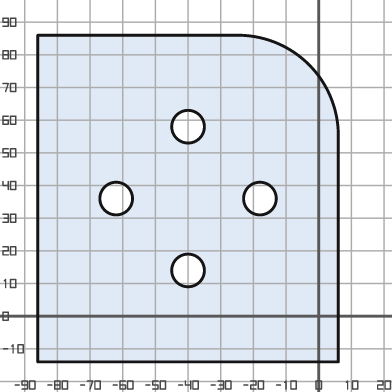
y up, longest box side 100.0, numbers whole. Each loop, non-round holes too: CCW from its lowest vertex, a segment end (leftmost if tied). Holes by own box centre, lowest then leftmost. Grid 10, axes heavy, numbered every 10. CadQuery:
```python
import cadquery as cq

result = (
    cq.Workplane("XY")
    .moveTo(-86.0, -14.0)
    .lineTo(6.0, -14.0)
    .lineTo(6.0, 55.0)
    .threePointArc((-3.0, 77.0), (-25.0, 86.0))
    .lineTo(-86.0, 86.0)
    .close()
    .moveTo(-40.0, 14.0)
    .circle(5.0)
    .moveTo(-62.0, 36.0)
    .circle(5.0)
    .moveTo(-18.0, 36.0)
    .circle(5.0)
    .moveTo(-40.0, 58.0)
    .circle(5.0)
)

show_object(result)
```